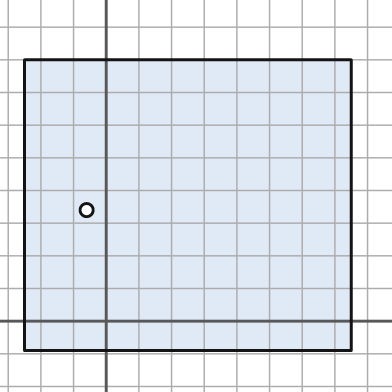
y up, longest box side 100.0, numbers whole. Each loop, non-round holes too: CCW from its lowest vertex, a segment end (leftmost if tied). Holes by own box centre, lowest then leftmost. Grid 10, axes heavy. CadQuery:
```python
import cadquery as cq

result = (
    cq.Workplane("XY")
    .moveTo(-25.0, -9.0)
    .lineTo(75.0, -9.0)
    .lineTo(75.0, 80.0)
    .lineTo(-25.0, 80.0)
    .close()
    .moveTo(-6.0, 34.0)
    .circle(2.0)
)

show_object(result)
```